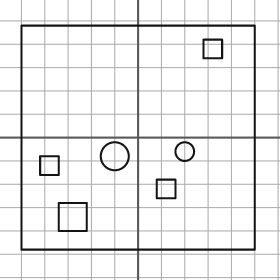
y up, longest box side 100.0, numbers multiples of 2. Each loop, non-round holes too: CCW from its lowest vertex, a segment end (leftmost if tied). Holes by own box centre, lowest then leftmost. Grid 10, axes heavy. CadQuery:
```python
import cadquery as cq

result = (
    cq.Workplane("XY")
    .moveTo(-50.0, -48.0)
    .lineTo(50.0, -48.0)
    .lineTo(50.0, 48.0)
    .lineTo(-50.0, 48.0)
    .close()
    .moveTo(-34.0, -40.0)
    .lineTo(-22.0, -40.0)
    .lineTo(-22.0, -28.0)
    .lineTo(-34.0, -28.0)
    .close()
    .moveTo(8.0, -26.0)
    .lineTo(16.0, -26.0)
    .lineTo(16.0, -18.0)
    .lineTo(8.0, -18.0)
    .close()
    .moveTo(-42.0, -16.0)
    .lineTo(-34.0, -16.0)
    .lineTo(-34.0, -8.0)
    .lineTo(-42.0, -8.0)
    .close()
    .moveTo(-10.0, -8.0)
    .circle(6.0)
    .moveTo(20.0, -6.0)
    .circle(4.0)
    .moveTo(28.0, 34.0)
    .lineTo(36.0, 34.0)
    .lineTo(36.0, 42.0)
    .lineTo(28.0, 42.0)
    .close()
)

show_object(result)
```